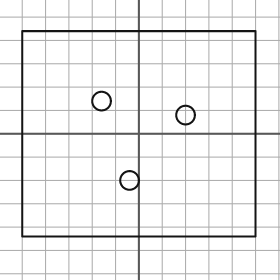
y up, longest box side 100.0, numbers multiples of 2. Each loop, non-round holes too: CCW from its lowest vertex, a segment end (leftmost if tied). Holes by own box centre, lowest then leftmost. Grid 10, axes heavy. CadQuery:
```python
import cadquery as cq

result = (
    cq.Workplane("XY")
    .moveTo(-50.0, -44.0)
    .lineTo(50.0, -44.0)
    .lineTo(50.0, 44.0)
    .lineTo(-50.0, 44.0)
    .close()
    .moveTo(-4.0, -20.0)
    .circle(4.0)
    .moveTo(20.0, 8.0)
    .circle(4.0)
    .moveTo(-16.0, 14.0)
    .circle(4.0)
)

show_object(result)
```